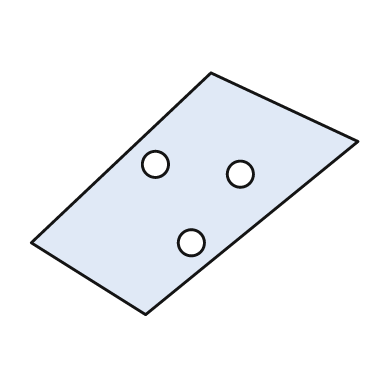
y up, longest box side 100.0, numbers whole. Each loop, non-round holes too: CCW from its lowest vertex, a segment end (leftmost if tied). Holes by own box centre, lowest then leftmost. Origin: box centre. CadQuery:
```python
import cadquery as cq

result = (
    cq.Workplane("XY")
    .moveTo(-15.0, -37.0)
    .lineTo(50.0, 16.0)
    .lineTo(5.0, 37.0)
    .lineTo(-50.0, -15.0)
    .close()
    .moveTo(-1.0, -15.0)
    .circle(4.0)
    .moveTo(14.0, 6.0)
    .circle(4.0)
    .moveTo(-12.0, 9.0)
    .circle(4.0)
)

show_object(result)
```